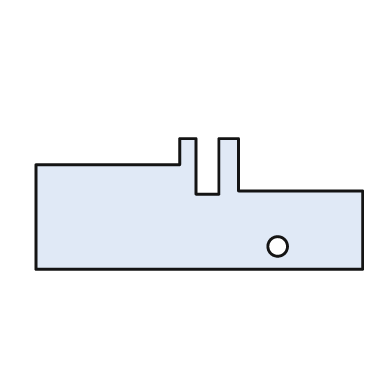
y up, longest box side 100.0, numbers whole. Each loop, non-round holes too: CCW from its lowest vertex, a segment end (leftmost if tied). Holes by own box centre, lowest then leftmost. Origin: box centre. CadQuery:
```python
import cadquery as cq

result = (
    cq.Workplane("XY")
    .moveTo(-50.0, -20.0)
    .lineTo(50.0, -20.0)
    .lineTo(50.0, 4.0)
    .lineTo(12.0, 4.0)
    .lineTo(12.0, 20.0)
    .lineTo(6.0, 20.0)
    .lineTo(6.0, 3.0)
    .lineTo(-1.0, 3.0)
    .lineTo(-1.0, 20.0)
    .lineTo(-6.0, 20.0)
    .lineTo(-6.0, 12.0)
    .lineTo(-50.0, 12.0)
    .close()
    .moveTo(24.0, -13.0)
    .circle(3.0)
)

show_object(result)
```